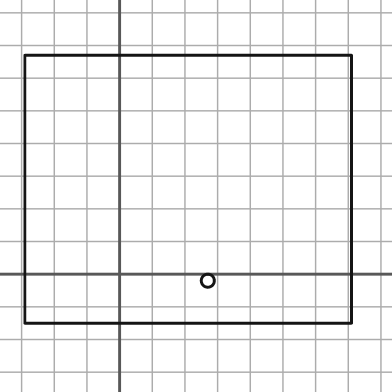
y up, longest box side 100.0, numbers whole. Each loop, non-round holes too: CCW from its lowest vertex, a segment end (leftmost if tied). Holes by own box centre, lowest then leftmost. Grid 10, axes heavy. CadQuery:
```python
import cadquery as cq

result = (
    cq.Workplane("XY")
    .moveTo(-29.0, -15.0)
    .lineTo(71.0, -15.0)
    .lineTo(71.0, 67.0)
    .lineTo(-29.0, 67.0)
    .close()
    .moveTo(27.0, -2.0)
    .circle(2.0)
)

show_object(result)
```